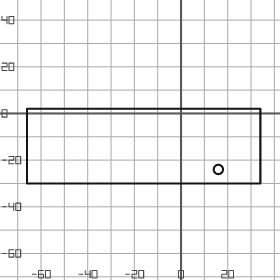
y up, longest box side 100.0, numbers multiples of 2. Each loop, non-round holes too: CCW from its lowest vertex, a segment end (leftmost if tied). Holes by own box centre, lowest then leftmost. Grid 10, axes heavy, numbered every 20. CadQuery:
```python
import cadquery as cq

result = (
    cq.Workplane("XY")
    .moveTo(-66.0, -30.0)
    .lineTo(34.0, -30.0)
    .lineTo(34.0, 2.0)
    .lineTo(-66.0, 2.0)
    .close()
    .moveTo(16.0, -24.0)
    .circle(2.0)
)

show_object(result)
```